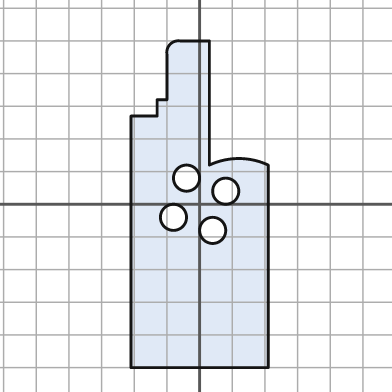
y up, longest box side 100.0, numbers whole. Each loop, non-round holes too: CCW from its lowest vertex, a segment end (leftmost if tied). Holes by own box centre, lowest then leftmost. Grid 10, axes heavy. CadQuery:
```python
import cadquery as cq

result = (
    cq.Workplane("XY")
    .moveTo(-21.0, -50.0)
    .lineTo(21.0, -50.0)
    .lineTo(21.0, 12.0)
    .threePointArc((12.0, 14.0), (3.0, 12.0))
    .lineTo(3.0, 50.0)
    .lineTo(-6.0, 50.0)
    .threePointArc((-9.0, 49.0), (-10.0, 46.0))
    .lineTo(-10.0, 32.0)
    .lineTo(-13.0, 32.0)
    .lineTo(-13.0, 27.0)
    .lineTo(-21.0, 27.0)
    .close()
    .moveTo(4.0, -8.0)
    .circle(4.0)
    .moveTo(-8.0, -4.0)
    .circle(4.0)
    .moveTo(8.0, 4.0)
    .circle(4.0)
    .moveTo(-4.0, 8.0)
    .circle(4.0)
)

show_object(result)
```